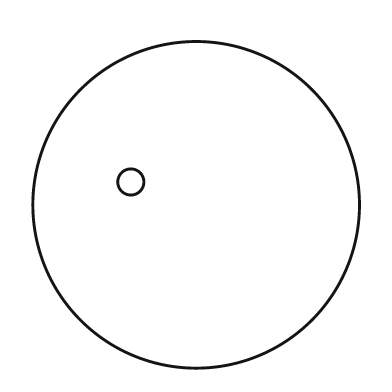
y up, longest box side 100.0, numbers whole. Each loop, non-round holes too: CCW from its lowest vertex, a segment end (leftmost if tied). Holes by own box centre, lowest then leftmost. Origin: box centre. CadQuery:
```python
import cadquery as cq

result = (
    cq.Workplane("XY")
    .moveTo(0.0, 0.0)
    .circle(50.0)
    .moveTo(-20.0, 7.0)
    .circle(4.0)
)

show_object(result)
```